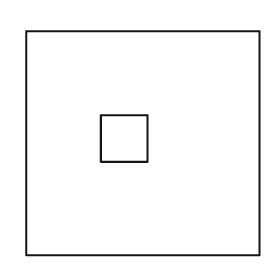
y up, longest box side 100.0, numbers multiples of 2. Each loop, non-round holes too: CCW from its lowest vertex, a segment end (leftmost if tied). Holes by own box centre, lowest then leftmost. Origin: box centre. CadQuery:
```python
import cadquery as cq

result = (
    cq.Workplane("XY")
    .moveTo(-50.0, -48.0)
    .lineTo(50.0, -48.0)
    .lineTo(50.0, 48.0)
    .lineTo(-50.0, 48.0)
    .close()
    .moveTo(-18.0, -8.0)
    .lineTo(2.0, -8.0)
    .lineTo(2.0, 12.0)
    .lineTo(-18.0, 12.0)
    .close()
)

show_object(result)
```